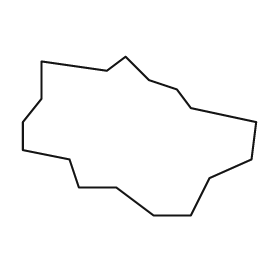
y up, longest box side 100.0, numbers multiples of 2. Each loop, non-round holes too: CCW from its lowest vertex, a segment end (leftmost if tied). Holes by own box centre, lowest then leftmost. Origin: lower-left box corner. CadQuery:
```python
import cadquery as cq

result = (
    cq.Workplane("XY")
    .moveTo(56.0, 0.0)
    .lineTo(72.0, 0.0)
    .lineTo(80.0, 16.0)
    .lineTo(98.0, 24.0)
    .lineTo(100.0, 40.0)
    .lineTo(72.0, 46.0)
    .lineTo(66.0, 54.0)
    .lineTo(54.0, 58.0)
    .lineTo(44.0, 68.0)
    .lineTo(36.0, 62.0)
    .lineTo(8.0, 66.0)
    .lineTo(8.0, 50.0)
    .lineTo(0.0, 40.0)
    .lineTo(0.0, 28.0)
    .lineTo(20.0, 24.0)
    .lineTo(24.0, 12.0)
    .lineTo(40.0, 12.0)
    .close()
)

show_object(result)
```